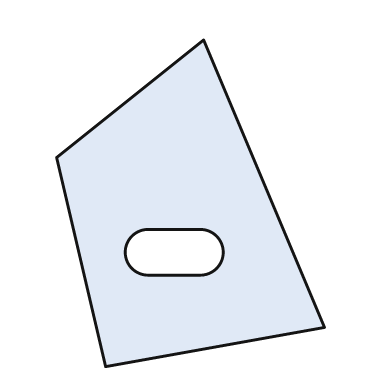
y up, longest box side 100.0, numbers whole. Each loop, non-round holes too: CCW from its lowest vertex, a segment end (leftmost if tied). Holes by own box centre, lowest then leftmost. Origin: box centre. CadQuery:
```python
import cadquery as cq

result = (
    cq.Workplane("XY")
    .moveTo(-26.0, -50.0)
    .lineTo(41.0, -38.0)
    .lineTo(4.0, 50.0)
    .lineTo(-41.0, 14.0)
    .close()
    .moveTo(-13.0, -22.0)
    .lineTo(3.0, -22.0)
    .threePointArc((10.0, -15.0), (3.0, -8.0))
    .lineTo(-13.0, -8.0)
    .threePointArc((-20.0, -15.0), (-13.0, -22.0))
    .close()
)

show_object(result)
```